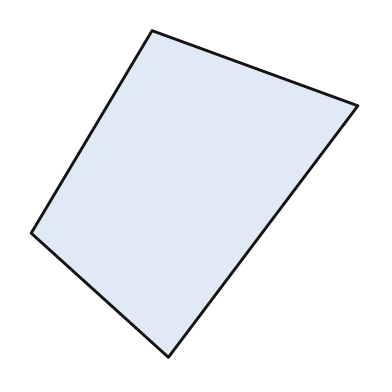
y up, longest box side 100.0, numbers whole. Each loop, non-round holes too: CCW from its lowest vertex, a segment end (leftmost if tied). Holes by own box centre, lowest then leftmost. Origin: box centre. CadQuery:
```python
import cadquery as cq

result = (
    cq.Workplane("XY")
    .moveTo(-8.0, -50.0)
    .lineTo(50.0, 27.0)
    .lineTo(-13.0, 50.0)
    .lineTo(-50.0, -12.0)
    .close()
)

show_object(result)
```